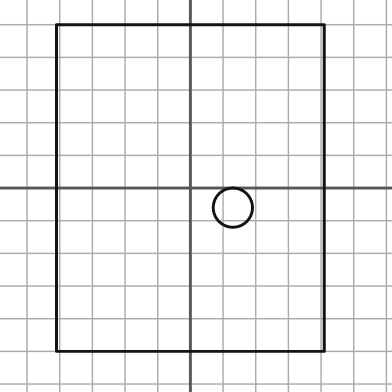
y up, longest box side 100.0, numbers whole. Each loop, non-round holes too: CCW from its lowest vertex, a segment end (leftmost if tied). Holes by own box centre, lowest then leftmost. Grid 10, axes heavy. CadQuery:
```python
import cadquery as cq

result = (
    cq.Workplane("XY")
    .moveTo(-41.0, -50.0)
    .lineTo(41.0, -50.0)
    .lineTo(41.0, 50.0)
    .lineTo(-41.0, 50.0)
    .close()
    .moveTo(13.0, -6.0)
    .circle(6.0)
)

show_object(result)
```